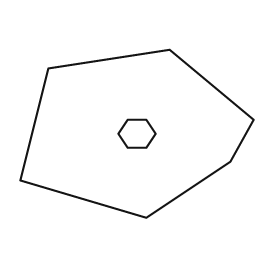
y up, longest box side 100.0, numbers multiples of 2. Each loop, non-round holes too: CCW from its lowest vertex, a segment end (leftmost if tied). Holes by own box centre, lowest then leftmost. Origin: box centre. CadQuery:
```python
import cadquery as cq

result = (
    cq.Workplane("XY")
    .moveTo(4.0, -36.0)
    .lineTo(40.0, -12.0)
    .lineTo(50.0, 6.0)
    .lineTo(14.0, 36.0)
    .lineTo(-38.0, 28.0)
    .lineTo(-50.0, -20.0)
    .close()
    .moveTo(-4.0, -6.0)
    .lineTo(4.0, -6.0)
    .lineTo(8.0, 0.0)
    .lineTo(4.0, 6.0)
    .lineTo(-4.0, 6.0)
    .lineTo(-8.0, 0.0)
    .close()
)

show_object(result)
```